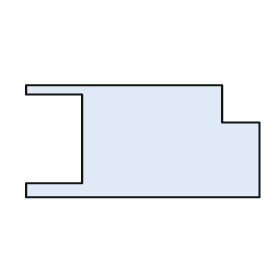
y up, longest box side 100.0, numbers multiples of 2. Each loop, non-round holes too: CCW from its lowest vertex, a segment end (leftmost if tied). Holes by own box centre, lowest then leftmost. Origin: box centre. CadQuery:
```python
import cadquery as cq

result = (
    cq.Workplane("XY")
    .moveTo(-50.0, -24.0)
    .lineTo(50.0, -24.0)
    .lineTo(50.0, 8.0)
    .lineTo(34.0, 8.0)
    .lineTo(34.0, 24.0)
    .lineTo(-50.0, 24.0)
    .lineTo(-50.0, 20.0)
    .lineTo(-26.0, 20.0)
    .lineTo(-26.0, -18.0)
    .lineTo(-50.0, -18.0)
    .close()
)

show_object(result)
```